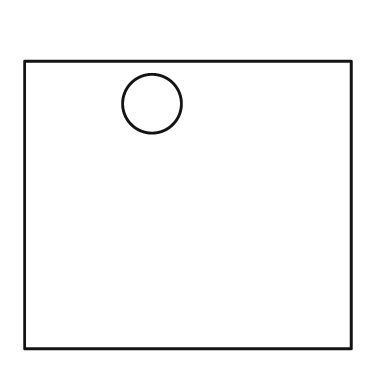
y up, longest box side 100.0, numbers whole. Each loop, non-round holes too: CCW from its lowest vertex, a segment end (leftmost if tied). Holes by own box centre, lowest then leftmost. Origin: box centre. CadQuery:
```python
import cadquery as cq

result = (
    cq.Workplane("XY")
    .moveTo(-50.0, -44.0)
    .lineTo(50.0, -44.0)
    .lineTo(50.0, 44.0)
    .lineTo(-50.0, 44.0)
    .close()
    .moveTo(-11.0, 31.0)
    .circle(9.0)
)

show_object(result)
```